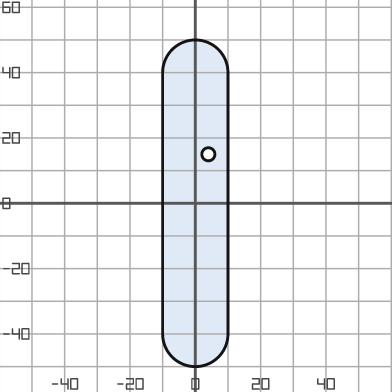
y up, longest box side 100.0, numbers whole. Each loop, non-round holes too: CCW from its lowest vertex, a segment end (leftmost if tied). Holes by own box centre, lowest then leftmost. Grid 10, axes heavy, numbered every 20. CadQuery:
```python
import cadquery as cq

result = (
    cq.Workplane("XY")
    .moveTo(-10.0, -40.0)
    .threePointArc((0.0, -50.0), (10.0, -40.0))
    .lineTo(10.0, 40.0)
    .threePointArc((0.0, 50.0), (-10.0, 40.0))
    .close()
    .moveTo(4.0, 15.0)
    .circle(2.0)
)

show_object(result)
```